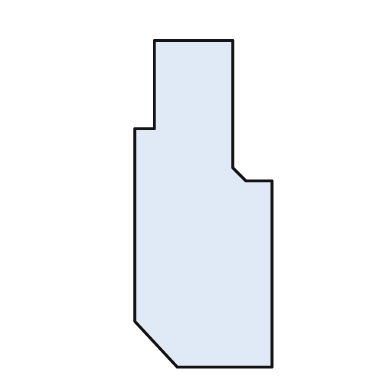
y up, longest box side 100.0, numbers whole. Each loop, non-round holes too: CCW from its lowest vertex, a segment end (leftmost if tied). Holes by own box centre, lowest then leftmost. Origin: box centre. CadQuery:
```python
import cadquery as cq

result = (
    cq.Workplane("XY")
    .moveTo(-8.0, -50.0)
    .lineTo(21.0, -50.0)
    .lineTo(21.0, 7.0)
    .lineTo(13.0, 7.0)
    .lineTo(9.0, 11.0)
    .lineTo(9.0, 50.0)
    .lineTo(-15.0, 50.0)
    .lineTo(-15.0, 23.0)
    .lineTo(-21.0, 23.0)
    .lineTo(-21.0, -36.0)
    .close()
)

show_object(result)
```